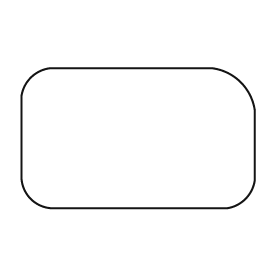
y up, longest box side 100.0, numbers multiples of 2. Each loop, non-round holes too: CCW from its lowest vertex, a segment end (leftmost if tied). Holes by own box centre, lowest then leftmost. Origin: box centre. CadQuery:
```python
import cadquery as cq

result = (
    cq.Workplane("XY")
    .moveTo(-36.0, -30.0)
    .lineTo(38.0, -30.0)
    .threePointArc((46.0, -26.0), (50.0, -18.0))
    .lineTo(50.0, 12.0)
    .threePointArc((44.0, 24.0), (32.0, 30.0))
    .lineTo(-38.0, 30.0)
    .threePointArc((-46.0, 26.0), (-50.0, 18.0))
    .lineTo(-50.0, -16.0)
    .threePointArc((-46.0, -26.0), (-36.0, -30.0))
    .close()
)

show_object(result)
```